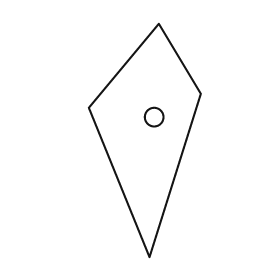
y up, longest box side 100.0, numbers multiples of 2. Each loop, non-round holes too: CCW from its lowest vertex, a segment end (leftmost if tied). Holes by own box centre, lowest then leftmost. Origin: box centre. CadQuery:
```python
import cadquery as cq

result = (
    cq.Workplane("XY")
    .moveTo(2.0, -50.0)
    .lineTo(24.0, 20.0)
    .lineTo(6.0, 50.0)
    .lineTo(-24.0, 14.0)
    .close()
    .moveTo(4.0, 10.0)
    .circle(4.0)
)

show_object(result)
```